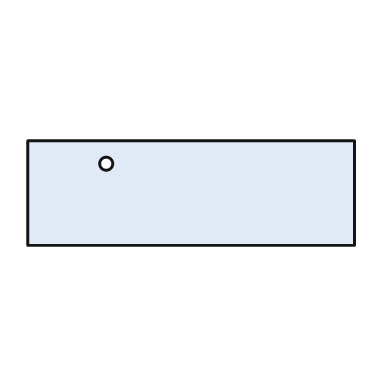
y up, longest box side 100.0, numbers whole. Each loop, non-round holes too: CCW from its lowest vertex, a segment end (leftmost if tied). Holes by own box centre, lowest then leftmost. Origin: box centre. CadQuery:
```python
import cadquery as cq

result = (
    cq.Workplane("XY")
    .moveTo(-50.0, -16.0)
    .lineTo(50.0, -16.0)
    .lineTo(50.0, 16.0)
    .lineTo(-50.0, 16.0)
    .close()
    .moveTo(-26.0, 9.0)
    .circle(2.0)
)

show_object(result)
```